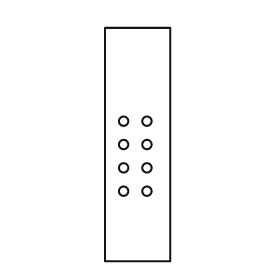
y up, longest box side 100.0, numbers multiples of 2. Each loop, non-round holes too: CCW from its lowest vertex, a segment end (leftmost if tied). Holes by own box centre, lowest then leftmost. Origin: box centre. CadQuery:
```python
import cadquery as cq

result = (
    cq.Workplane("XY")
    .moveTo(-14.0, -50.0)
    .lineTo(14.0, -50.0)
    .lineTo(14.0, 50.0)
    .lineTo(-14.0, 50.0)
    .close()
    .moveTo(-6.0, -20.0)
    .circle(2.0)
    .moveTo(4.0, -20.0)
    .circle(2.0)
    .moveTo(-6.0, -10.0)
    .circle(2.0)
    .moveTo(4.0, -10.0)
    .circle(2.0)
    .moveTo(-6.0, 0.0)
    .circle(2.0)
    .moveTo(4.0, 0.0)
    .circle(2.0)
    .moveTo(-6.0, 10.0)
    .circle(2.0)
    .moveTo(4.0, 10.0)
    .circle(2.0)
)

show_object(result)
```